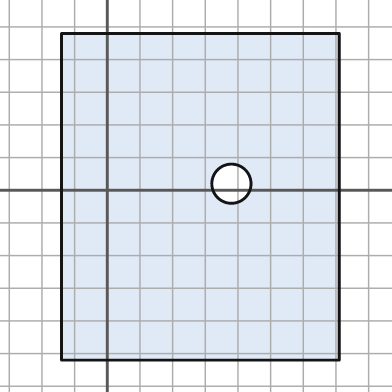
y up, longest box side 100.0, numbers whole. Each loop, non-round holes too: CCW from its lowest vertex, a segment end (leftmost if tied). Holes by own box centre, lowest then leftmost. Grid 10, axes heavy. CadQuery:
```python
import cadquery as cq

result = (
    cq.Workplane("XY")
    .moveTo(-14.0, -52.0)
    .lineTo(71.0, -52.0)
    .lineTo(71.0, 48.0)
    .lineTo(-14.0, 48.0)
    .close()
    .moveTo(38.0, 2.0)
    .circle(6.0)
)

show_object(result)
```